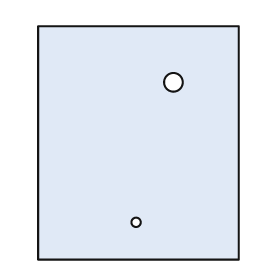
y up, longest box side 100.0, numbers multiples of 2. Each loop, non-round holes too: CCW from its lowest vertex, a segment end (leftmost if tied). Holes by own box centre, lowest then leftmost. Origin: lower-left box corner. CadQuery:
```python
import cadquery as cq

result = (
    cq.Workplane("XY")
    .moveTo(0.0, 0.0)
    .lineTo(86.0, 0.0)
    .lineTo(86.0, 100.0)
    .lineTo(0.0, 100.0)
    .close()
    .moveTo(42.0, 16.0)
    .circle(2.0)
    .moveTo(58.0, 76.0)
    .circle(4.0)
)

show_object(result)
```